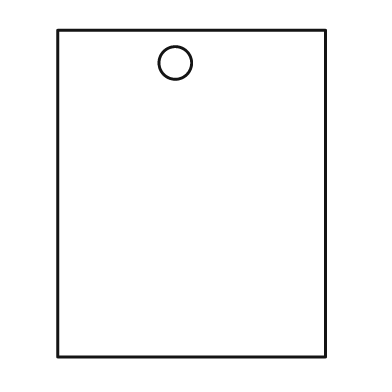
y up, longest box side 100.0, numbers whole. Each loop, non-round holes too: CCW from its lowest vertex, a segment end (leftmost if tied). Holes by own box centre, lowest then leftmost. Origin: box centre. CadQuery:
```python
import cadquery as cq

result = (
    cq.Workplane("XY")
    .moveTo(-41.0, -50.0)
    .lineTo(41.0, -50.0)
    .lineTo(41.0, 50.0)
    .lineTo(-41.0, 50.0)
    .close()
    .moveTo(-5.0, 40.0)
    .circle(5.0)
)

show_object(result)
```